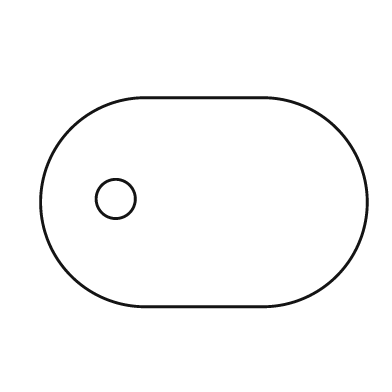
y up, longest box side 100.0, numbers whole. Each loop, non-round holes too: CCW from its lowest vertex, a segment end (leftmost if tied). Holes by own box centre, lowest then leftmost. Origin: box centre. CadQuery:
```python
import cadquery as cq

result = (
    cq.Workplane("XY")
    .moveTo(-18.0, -32.0)
    .lineTo(18.0, -32.0)
    .threePointArc((50.0, 0.0), (18.0, 32.0))
    .lineTo(-18.0, 32.0)
    .threePointArc((-50.0, 0.0), (-18.0, -32.0))
    .close()
    .moveTo(-27.0, 1.0)
    .circle(6.0)
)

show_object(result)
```